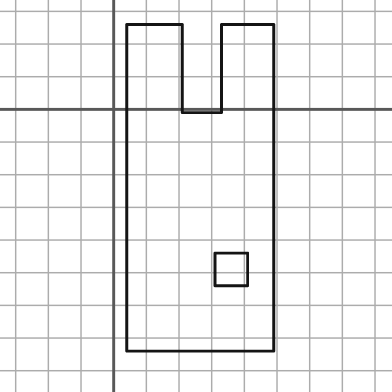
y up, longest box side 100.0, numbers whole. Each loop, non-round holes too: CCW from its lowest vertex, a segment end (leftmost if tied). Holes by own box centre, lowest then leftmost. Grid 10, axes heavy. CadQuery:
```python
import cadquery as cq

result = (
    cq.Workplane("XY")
    .moveTo(4.0, -74.0)
    .lineTo(49.0, -74.0)
    .lineTo(49.0, 26.0)
    .lineTo(33.0, 26.0)
    .lineTo(33.0, -1.0)
    .lineTo(21.0, -1.0)
    .lineTo(21.0, 26.0)
    .lineTo(4.0, 26.0)
    .close()
    .moveTo(31.0, -54.0)
    .lineTo(41.0, -54.0)
    .lineTo(41.0, -44.0)
    .lineTo(31.0, -44.0)
    .close()
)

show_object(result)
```